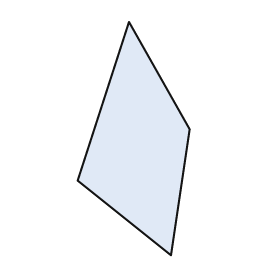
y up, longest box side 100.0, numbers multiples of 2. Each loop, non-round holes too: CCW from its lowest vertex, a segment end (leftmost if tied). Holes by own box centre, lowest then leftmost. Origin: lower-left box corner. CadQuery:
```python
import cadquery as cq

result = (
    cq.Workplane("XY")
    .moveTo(40.0, 0.0)
    .lineTo(48.0, 54.0)
    .lineTo(22.0, 100.0)
    .lineTo(0.0, 32.0)
    .close()
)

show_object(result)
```